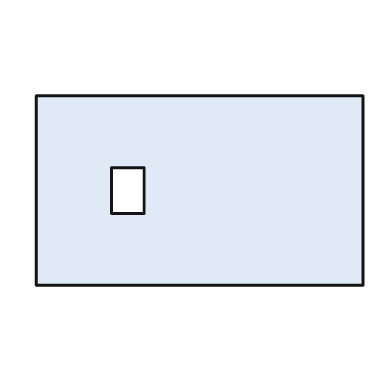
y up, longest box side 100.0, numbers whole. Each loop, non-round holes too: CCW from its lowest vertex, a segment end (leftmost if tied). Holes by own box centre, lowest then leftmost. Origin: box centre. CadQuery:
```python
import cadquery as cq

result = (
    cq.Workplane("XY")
    .moveTo(-50.0, -29.0)
    .lineTo(50.0, -29.0)
    .lineTo(50.0, 29.0)
    .lineTo(-50.0, 29.0)
    .close()
    .moveTo(-27.0, -7.0)
    .lineTo(-17.0, -7.0)
    .lineTo(-17.0, 7.0)
    .lineTo(-27.0, 7.0)
    .close()
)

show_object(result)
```